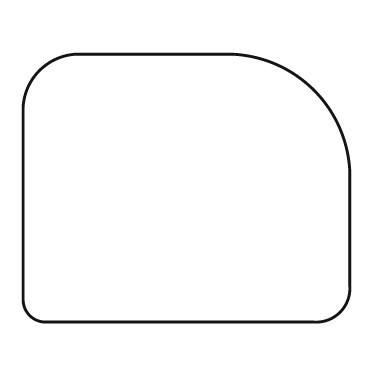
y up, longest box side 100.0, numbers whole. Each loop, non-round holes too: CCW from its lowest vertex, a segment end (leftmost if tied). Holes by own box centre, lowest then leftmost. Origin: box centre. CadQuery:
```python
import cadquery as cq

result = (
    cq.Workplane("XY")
    .moveTo(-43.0, -41.0)
    .lineTo(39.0, -41.0)
    .threePointArc((47.0, -38.0), (50.0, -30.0))
    .lineTo(50.0, 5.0)
    .threePointArc((39.0, 30.0), (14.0, 41.0))
    .lineTo(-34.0, 41.0)
    .threePointArc((-45.0, 36.0), (-50.0, 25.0))
    .lineTo(-50.0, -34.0)
    .threePointArc((-48.0, -39.0), (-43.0, -41.0))
    .close()
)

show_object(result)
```